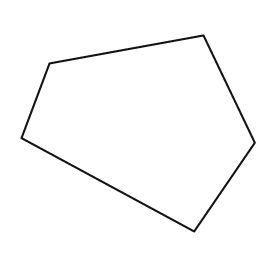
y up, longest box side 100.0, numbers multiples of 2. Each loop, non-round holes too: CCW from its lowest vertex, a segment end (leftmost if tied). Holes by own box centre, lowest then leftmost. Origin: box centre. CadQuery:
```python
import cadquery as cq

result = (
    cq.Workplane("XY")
    .moveTo(24.0, -42.0)
    .lineTo(50.0, -4.0)
    .lineTo(28.0, 42.0)
    .lineTo(-38.0, 30.0)
    .lineTo(-50.0, -2.0)
    .close()
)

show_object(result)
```